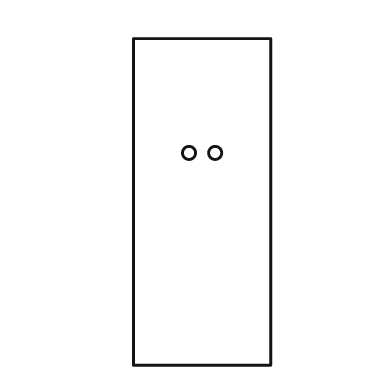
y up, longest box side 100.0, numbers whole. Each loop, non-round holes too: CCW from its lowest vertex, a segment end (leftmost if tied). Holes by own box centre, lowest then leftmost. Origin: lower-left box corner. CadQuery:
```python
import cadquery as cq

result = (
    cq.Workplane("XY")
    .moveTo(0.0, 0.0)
    .lineTo(42.0, 0.0)
    .lineTo(42.0, 100.0)
    .lineTo(0.0, 100.0)
    .close()
    .moveTo(17.0, 65.0)
    .circle(2.0)
    .moveTo(25.0, 65.0)
    .circle(2.0)
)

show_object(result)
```